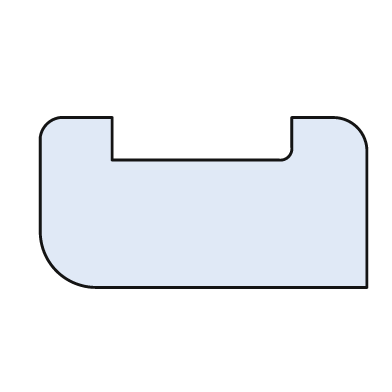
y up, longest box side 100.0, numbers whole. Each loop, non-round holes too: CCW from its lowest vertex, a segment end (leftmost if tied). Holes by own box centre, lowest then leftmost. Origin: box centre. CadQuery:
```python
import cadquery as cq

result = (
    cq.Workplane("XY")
    .moveTo(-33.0, -26.0)
    .lineTo(50.0, -26.0)
    .lineTo(50.0, 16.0)
    .threePointArc((47.0, 23.0), (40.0, 26.0))
    .lineTo(27.0, 26.0)
    .lineTo(27.0, 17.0)
    .threePointArc((26.0, 14.0), (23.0, 13.0))
    .lineTo(-28.0, 13.0)
    .lineTo(-28.0, 26.0)
    .lineTo(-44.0, 26.0)
    .threePointArc((-48.0, 24.0), (-50.0, 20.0))
    .lineTo(-50.0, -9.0)
    .threePointArc((-45.0, -21.0), (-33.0, -26.0))
    .close()
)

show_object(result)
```